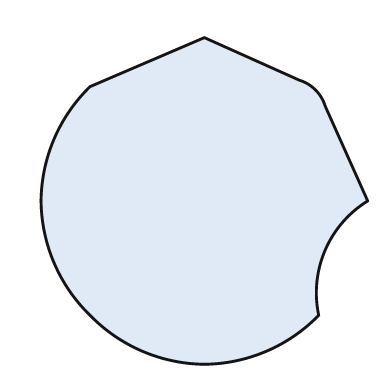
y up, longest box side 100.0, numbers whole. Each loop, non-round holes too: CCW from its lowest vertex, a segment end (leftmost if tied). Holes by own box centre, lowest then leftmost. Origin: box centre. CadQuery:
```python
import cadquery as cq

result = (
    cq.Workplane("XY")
    .moveTo(0.0, -50.0)
    .threePointArc((19.0, -46.0), (35.0, -35.0))
    .threePointArc((37.0, -15.0), (50.0, 0.0))
    .lineTo(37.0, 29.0)
    .threePointArc((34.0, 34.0), (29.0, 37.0))
    .lineTo(0.0, 50.0)
    .lineTo(-35.0, 35.0)
    .threePointArc((-46.0, 19.0), (-50.0, 0.0))
    .threePointArc((-46.0, -19.0), (-35.0, -35.0))
    .threePointArc((-19.0, -46.0), (0.0, -50.0))
    .close()
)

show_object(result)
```